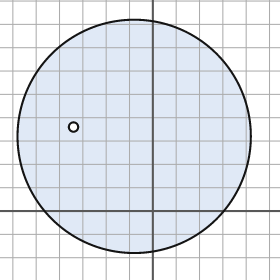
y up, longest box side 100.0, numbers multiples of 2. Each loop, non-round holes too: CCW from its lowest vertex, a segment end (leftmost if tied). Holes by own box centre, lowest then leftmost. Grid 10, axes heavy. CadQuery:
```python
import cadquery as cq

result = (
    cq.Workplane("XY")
    .moveTo(-8.0, 32.0)
    .circle(50.0)
    .moveTo(-34.0, 36.0)
    .circle(2.0)
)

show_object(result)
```